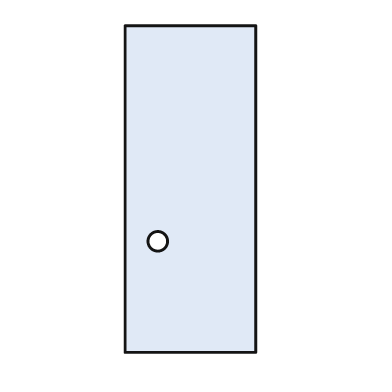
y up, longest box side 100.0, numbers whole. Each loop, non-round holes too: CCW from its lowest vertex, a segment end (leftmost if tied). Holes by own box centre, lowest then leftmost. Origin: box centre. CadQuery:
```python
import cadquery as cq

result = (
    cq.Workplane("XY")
    .moveTo(-20.0, -50.0)
    .lineTo(20.0, -50.0)
    .lineTo(20.0, 50.0)
    .lineTo(-20.0, 50.0)
    .close()
    .moveTo(-10.0, -16.0)
    .circle(3.0)
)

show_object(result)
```